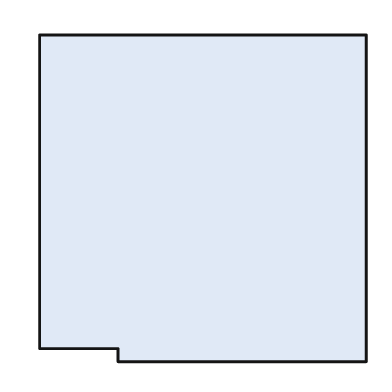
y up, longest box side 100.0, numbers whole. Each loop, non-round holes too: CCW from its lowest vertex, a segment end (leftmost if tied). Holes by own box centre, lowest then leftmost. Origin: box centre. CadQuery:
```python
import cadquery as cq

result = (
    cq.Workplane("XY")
    .moveTo(-26.0, -50.0)
    .lineTo(50.0, -50.0)
    .lineTo(50.0, 50.0)
    .lineTo(-50.0, 50.0)
    .lineTo(-50.0, -46.0)
    .lineTo(-26.0, -46.0)
    .close()
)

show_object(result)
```